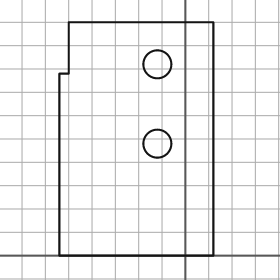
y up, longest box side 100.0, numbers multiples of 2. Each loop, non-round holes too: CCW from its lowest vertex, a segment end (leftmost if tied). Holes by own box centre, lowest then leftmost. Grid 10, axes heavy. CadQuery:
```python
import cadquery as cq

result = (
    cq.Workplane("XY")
    .moveTo(-54.0, 0.0)
    .lineTo(12.0, 0.0)
    .lineTo(12.0, 100.0)
    .lineTo(-50.0, 100.0)
    .lineTo(-50.0, 78.0)
    .lineTo(-54.0, 78.0)
    .close()
    .moveTo(-12.0, 48.0)
    .circle(6.0)
    .moveTo(-12.0, 82.0)
    .circle(6.0)
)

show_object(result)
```